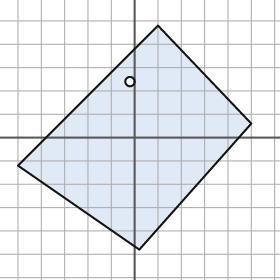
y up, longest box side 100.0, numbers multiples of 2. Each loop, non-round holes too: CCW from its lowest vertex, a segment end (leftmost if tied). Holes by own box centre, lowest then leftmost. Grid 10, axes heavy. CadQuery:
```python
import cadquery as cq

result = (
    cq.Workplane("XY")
    .moveTo(2.0, -48.0)
    .lineTo(50.0, 6.0)
    .lineTo(10.0, 48.0)
    .lineTo(-50.0, -12.0)
    .close()
    .moveTo(-2.0, 24.0)
    .circle(2.0)
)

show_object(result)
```